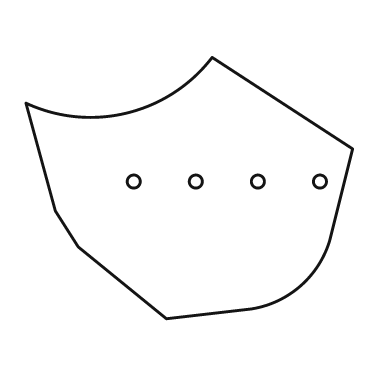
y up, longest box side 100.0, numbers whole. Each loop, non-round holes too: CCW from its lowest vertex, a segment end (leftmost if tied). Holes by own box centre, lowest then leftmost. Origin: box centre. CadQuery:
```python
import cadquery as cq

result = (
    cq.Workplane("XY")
    .moveTo(-7.0, -40.0)
    .lineTo(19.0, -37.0)
    .threePointArc((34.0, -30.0), (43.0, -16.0))
    .lineTo(50.0, 12.0)
    .lineTo(7.0, 40.0)
    .threePointArc((-19.0, 23.0), (-50.0, 26.0))
    .lineTo(-41.0, -7.0)
    .lineTo(-34.0, -18.0)
    .close()
    .moveTo(-17.0, 2.0)
    .circle(2.0)
    .moveTo(2.0, 2.0)
    .circle(2.0)
    .moveTo(21.0, 2.0)
    .circle(2.0)
    .moveTo(40.0, 2.0)
    .circle(2.0)
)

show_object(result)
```